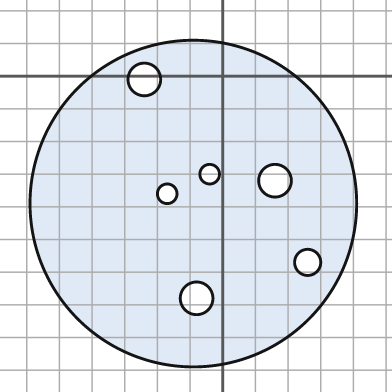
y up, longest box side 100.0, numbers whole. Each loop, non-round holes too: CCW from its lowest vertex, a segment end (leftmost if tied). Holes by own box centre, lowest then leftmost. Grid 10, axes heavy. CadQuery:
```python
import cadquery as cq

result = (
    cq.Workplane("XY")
    .moveTo(-9.0, -39.0)
    .circle(50.0)
    .moveTo(-8.0, -68.0)
    .circle(5.0)
    .moveTo(26.0, -57.0)
    .circle(4.0)
    .moveTo(-17.0, -36.0)
    .circle(3.0)
    .moveTo(16.0, -32.0)
    .circle(5.0)
    .moveTo(-4.0, -30.0)
    .circle(3.0)
    .moveTo(-24.0, -1.0)
    .circle(5.0)
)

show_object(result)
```